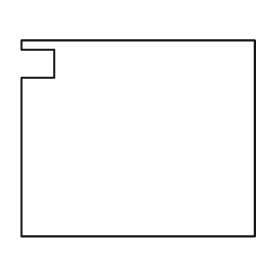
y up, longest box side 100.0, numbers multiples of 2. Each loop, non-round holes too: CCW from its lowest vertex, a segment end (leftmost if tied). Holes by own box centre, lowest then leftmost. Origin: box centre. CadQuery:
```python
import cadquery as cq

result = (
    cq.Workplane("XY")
    .moveTo(-50.0, -42.0)
    .lineTo(50.0, -42.0)
    .lineTo(50.0, 42.0)
    .lineTo(-50.0, 42.0)
    .lineTo(-50.0, 38.0)
    .lineTo(-36.0, 38.0)
    .lineTo(-36.0, 26.0)
    .lineTo(-50.0, 26.0)
    .close()
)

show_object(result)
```